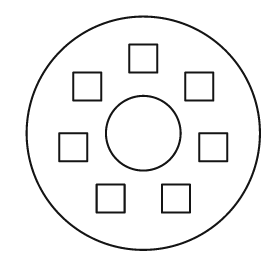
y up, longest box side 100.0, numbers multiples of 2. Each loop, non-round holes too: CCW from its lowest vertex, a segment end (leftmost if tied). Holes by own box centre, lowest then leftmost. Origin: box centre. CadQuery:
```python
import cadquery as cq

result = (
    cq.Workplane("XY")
    .moveTo(0.0, 0.0)
    .circle(50.0)
    .moveTo(-20.0, -34.0)
    .lineTo(-8.0, -34.0)
    .lineTo(-8.0, -22.0)
    .lineTo(-20.0, -22.0)
    .close()
    .moveTo(8.0, -34.0)
    .lineTo(20.0, -34.0)
    .lineTo(20.0, -22.0)
    .lineTo(8.0, -22.0)
    .close()
    .moveTo(-36.0, -12.0)
    .lineTo(-24.0, -12.0)
    .lineTo(-24.0, 0.0)
    .lineTo(-36.0, 0.0)
    .close()
    .moveTo(24.0, -12.0)
    .lineTo(36.0, -12.0)
    .lineTo(36.0, 0.0)
    .lineTo(24.0, 0.0)
    .close()
    .moveTo(0.0, 0.0)
    .circle(16.0)
    .moveTo(-30.0, 14.0)
    .lineTo(-18.0, 14.0)
    .lineTo(-18.0, 26.0)
    .lineTo(-30.0, 26.0)
    .close()
    .moveTo(18.0, 14.0)
    .lineTo(30.0, 14.0)
    .lineTo(30.0, 26.0)
    .lineTo(18.0, 26.0)
    .close()
    .moveTo(-6.0, 26.0)
    .lineTo(6.0, 26.0)
    .lineTo(6.0, 38.0)
    .lineTo(-6.0, 38.0)
    .close()
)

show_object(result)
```